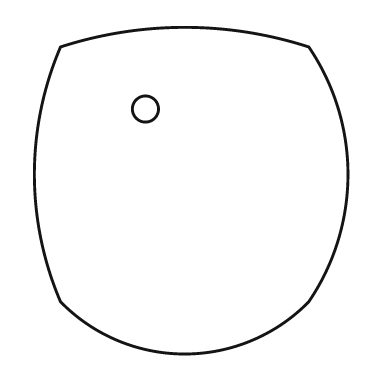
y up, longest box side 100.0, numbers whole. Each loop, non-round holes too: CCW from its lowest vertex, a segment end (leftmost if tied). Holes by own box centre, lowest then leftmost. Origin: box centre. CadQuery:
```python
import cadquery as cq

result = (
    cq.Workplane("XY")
    .moveTo(-40.0, -34.0)
    .threePointArc((-2.0, -50.0), (36.0, -34.0))
    .threePointArc((48.0, 5.0), (36.0, 44.0))
    .threePointArc((-2.0, 50.0), (-40.0, 44.0))
    .threePointArc((-48.0, 5.0), (-40.0, -34.0))
    .close()
    .moveTo(-14.0, 25.0)
    .circle(4.0)
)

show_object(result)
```